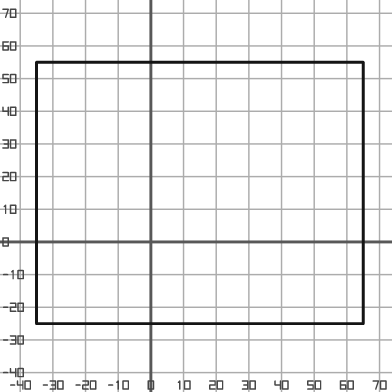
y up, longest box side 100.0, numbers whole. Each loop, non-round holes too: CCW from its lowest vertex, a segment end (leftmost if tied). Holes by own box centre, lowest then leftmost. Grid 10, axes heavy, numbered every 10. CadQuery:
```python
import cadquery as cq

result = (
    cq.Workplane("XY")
    .moveTo(-35.0, -25.0)
    .lineTo(65.0, -25.0)
    .lineTo(65.0, 55.0)
    .lineTo(-35.0, 55.0)
    .close()
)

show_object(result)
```